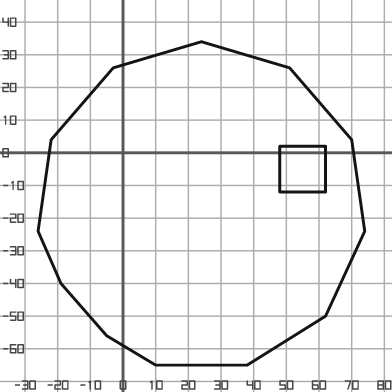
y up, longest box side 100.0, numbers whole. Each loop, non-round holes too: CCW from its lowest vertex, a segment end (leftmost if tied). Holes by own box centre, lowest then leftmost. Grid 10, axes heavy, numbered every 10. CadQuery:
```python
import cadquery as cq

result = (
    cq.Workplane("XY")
    .moveTo(10.0, -65.0)
    .lineTo(38.0, -65.0)
    .lineTo(62.0, -50.0)
    .lineTo(74.0, -24.0)
    .lineTo(70.0, 4.0)
    .lineTo(51.0, 26.0)
    .lineTo(24.0, 34.0)
    .lineTo(-3.0, 26.0)
    .lineTo(-22.0, 4.0)
    .lineTo(-26.0, -24.0)
    .lineTo(-19.0, -40.0)
    .lineTo(-5.0, -56.0)
    .close()
    .moveTo(48.0, -12.0)
    .lineTo(62.0, -12.0)
    .lineTo(62.0, 2.0)
    .lineTo(48.0, 2.0)
    .close()
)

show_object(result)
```